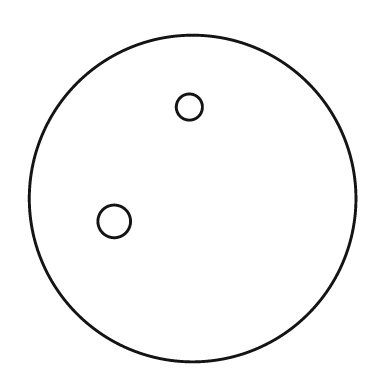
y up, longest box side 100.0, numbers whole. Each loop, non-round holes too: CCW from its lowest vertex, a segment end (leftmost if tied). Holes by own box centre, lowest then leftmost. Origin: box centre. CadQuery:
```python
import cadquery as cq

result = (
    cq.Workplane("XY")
    .moveTo(0.0, 0.0)
    .circle(50.0)
    .moveTo(-24.0, -7.0)
    .circle(5.0)
    .moveTo(-1.0, 28.0)
    .circle(4.0)
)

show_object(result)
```